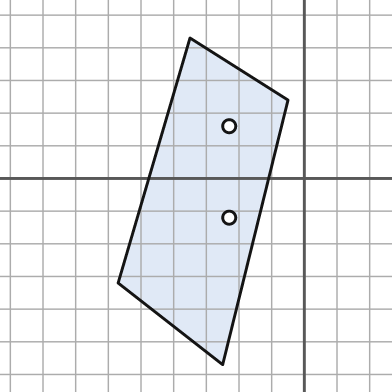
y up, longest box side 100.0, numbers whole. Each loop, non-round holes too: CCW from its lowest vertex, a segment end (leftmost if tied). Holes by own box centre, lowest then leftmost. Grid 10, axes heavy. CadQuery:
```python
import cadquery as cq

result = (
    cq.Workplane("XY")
    .moveTo(-25.0, -57.0)
    .lineTo(-5.0, 24.0)
    .lineTo(-35.0, 43.0)
    .lineTo(-57.0, -32.0)
    .close()
    .moveTo(-23.0, -12.0)
    .circle(2.0)
    .moveTo(-23.0, 16.0)
    .circle(2.0)
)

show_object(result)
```